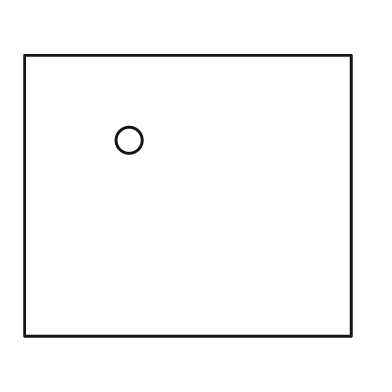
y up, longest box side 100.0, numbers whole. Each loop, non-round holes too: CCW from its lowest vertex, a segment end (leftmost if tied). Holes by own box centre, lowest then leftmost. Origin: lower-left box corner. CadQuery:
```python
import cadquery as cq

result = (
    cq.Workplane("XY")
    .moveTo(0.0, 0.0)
    .lineTo(100.0, 0.0)
    .lineTo(100.0, 86.0)
    .lineTo(0.0, 86.0)
    .close()
    .moveTo(32.0, 60.0)
    .circle(4.0)
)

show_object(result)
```